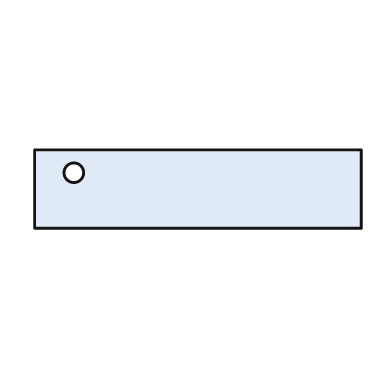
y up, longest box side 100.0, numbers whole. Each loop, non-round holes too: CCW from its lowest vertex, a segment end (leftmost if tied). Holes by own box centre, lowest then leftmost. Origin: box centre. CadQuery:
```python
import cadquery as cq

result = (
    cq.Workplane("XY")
    .moveTo(-50.0, -12.0)
    .lineTo(50.0, -12.0)
    .lineTo(50.0, 12.0)
    .lineTo(-50.0, 12.0)
    .close()
    .moveTo(-38.0, 5.0)
    .circle(3.0)
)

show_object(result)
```